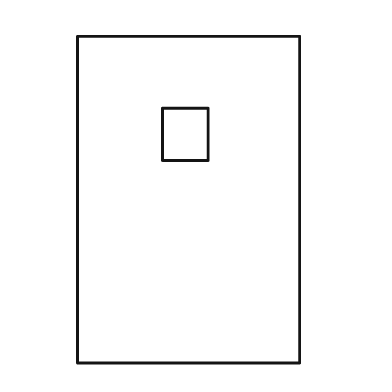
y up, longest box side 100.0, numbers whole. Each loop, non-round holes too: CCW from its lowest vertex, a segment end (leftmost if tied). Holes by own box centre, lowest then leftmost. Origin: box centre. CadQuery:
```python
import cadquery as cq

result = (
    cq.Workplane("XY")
    .moveTo(-34.0, -50.0)
    .lineTo(34.0, -50.0)
    .lineTo(34.0, 50.0)
    .lineTo(-34.0, 50.0)
    .close()
    .moveTo(-8.0, 12.0)
    .lineTo(6.0, 12.0)
    .lineTo(6.0, 28.0)
    .lineTo(-8.0, 28.0)
    .close()
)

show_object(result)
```